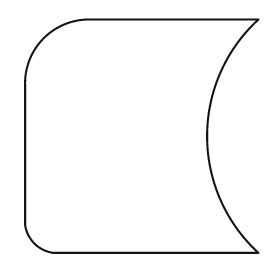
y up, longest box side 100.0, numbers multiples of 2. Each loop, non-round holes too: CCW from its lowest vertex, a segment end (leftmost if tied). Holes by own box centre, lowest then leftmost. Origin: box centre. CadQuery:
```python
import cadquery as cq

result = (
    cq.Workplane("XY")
    .moveTo(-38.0, -50.0)
    .lineTo(50.0, -50.0)
    .threePointArc((28.0, 0.0), (50.0, 50.0))
    .lineTo(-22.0, 50.0)
    .threePointArc((-42.0, 42.0), (-50.0, 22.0))
    .lineTo(-50.0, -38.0)
    .threePointArc((-46.0, -46.0), (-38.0, -50.0))
    .close()
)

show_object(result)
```